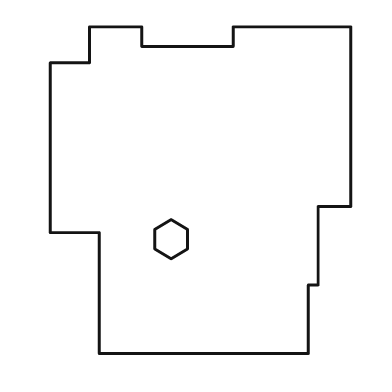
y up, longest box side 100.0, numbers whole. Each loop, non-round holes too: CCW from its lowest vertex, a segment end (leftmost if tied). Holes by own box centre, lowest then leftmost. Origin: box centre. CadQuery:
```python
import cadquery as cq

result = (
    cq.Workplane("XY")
    .moveTo(-31.0, -50.0)
    .lineTo(33.0, -50.0)
    .lineTo(33.0, -29.0)
    .lineTo(36.0, -29.0)
    .lineTo(36.0, -5.0)
    .lineTo(46.0, -5.0)
    .lineTo(46.0, 50.0)
    .lineTo(10.0, 50.0)
    .lineTo(10.0, 44.0)
    .lineTo(-18.0, 44.0)
    .lineTo(-18.0, 50.0)
    .lineTo(-34.0, 50.0)
    .lineTo(-34.0, 39.0)
    .lineTo(-46.0, 39.0)
    .lineTo(-46.0, -13.0)
    .lineTo(-31.0, -13.0)
    .close()
    .moveTo(-9.0, -21.0)
    .lineTo(-4.0, -18.0)
    .lineTo(-4.0, -12.0)
    .lineTo(-9.0, -9.0)
    .lineTo(-14.0, -12.0)
    .lineTo(-14.0, -18.0)
    .close()
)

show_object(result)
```